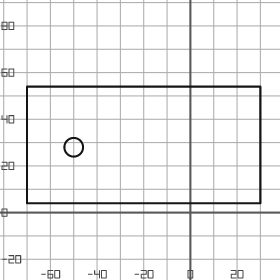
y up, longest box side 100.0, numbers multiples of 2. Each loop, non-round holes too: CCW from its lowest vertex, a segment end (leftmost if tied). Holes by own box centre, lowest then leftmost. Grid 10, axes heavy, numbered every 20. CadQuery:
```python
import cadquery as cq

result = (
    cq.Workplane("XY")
    .moveTo(-70.0, 4.0)
    .lineTo(30.0, 4.0)
    .lineTo(30.0, 54.0)
    .lineTo(-70.0, 54.0)
    .close()
    .moveTo(-50.0, 28.0)
    .circle(4.0)
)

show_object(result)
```